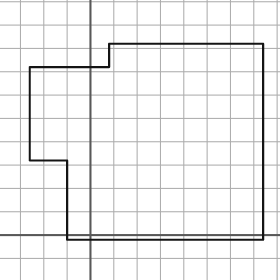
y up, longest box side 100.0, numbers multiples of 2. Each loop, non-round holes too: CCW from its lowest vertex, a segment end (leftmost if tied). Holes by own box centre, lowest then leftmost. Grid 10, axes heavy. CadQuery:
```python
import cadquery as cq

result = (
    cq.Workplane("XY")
    .moveTo(-10.0, -2.0)
    .lineTo(74.0, -2.0)
    .lineTo(74.0, 82.0)
    .lineTo(8.0, 82.0)
    .lineTo(8.0, 72.0)
    .lineTo(-26.0, 72.0)
    .lineTo(-26.0, 32.0)
    .lineTo(-10.0, 32.0)
    .close()
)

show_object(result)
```